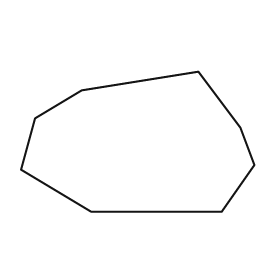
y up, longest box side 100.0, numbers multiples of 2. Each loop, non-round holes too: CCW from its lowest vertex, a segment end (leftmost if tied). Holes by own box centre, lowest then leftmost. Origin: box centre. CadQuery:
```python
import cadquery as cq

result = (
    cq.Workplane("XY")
    .moveTo(-20.0, -30.0)
    .lineTo(36.0, -30.0)
    .lineTo(50.0, -10.0)
    .lineTo(44.0, 6.0)
    .lineTo(26.0, 30.0)
    .lineTo(-24.0, 22.0)
    .lineTo(-44.0, 10.0)
    .lineTo(-50.0, -12.0)
    .close()
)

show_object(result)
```